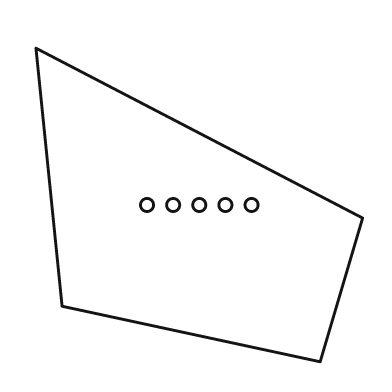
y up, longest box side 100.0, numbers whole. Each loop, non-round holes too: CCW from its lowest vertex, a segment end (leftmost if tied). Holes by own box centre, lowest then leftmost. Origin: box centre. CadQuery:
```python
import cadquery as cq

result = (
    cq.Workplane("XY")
    .moveTo(37.0, -48.0)
    .lineTo(50.0, -4.0)
    .lineTo(-50.0, 48.0)
    .lineTo(-42.0, -31.0)
    .close()
    .moveTo(-16.0, 0.0)
    .circle(2.0)
    .moveTo(-8.0, 0.0)
    .circle(2.0)
    .moveTo(0.0, 0.0)
    .circle(2.0)
    .moveTo(8.0, 0.0)
    .circle(2.0)
    .moveTo(16.0, 0.0)
    .circle(2.0)
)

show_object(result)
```